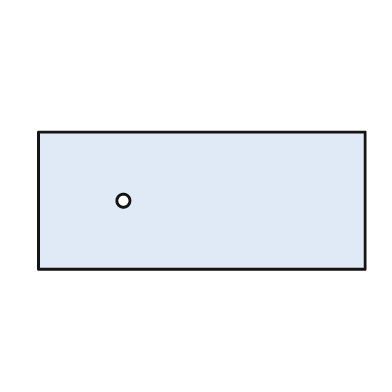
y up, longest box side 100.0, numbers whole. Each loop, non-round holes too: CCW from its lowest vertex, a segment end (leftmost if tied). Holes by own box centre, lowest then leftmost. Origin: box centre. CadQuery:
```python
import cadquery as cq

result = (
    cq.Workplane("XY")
    .moveTo(-50.0, -21.0)
    .lineTo(50.0, -21.0)
    .lineTo(50.0, 21.0)
    .lineTo(-50.0, 21.0)
    .close()
    .moveTo(-24.0, 0.0)
    .circle(2.0)
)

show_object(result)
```